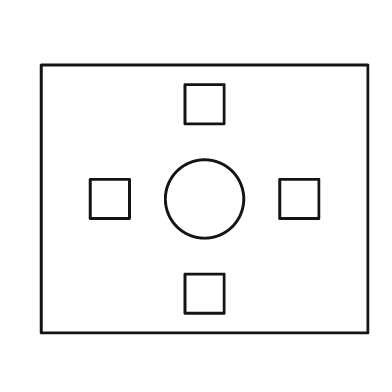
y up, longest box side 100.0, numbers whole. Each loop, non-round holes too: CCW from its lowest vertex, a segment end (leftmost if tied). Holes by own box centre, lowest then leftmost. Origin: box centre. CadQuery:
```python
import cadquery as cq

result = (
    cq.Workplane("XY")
    .moveTo(-50.0, -41.0)
    .lineTo(50.0, -41.0)
    .lineTo(50.0, 41.0)
    .lineTo(-50.0, 41.0)
    .close()
    .moveTo(-6.0, -35.0)
    .lineTo(6.0, -35.0)
    .lineTo(6.0, -23.0)
    .lineTo(-6.0, -23.0)
    .close()
    .moveTo(-35.0, -6.0)
    .lineTo(-23.0, -6.0)
    .lineTo(-23.0, 6.0)
    .lineTo(-35.0, 6.0)
    .close()
    .moveTo(0.0, 0.0)
    .circle(12.0)
    .moveTo(23.0, -6.0)
    .lineTo(35.0, -6.0)
    .lineTo(35.0, 6.0)
    .lineTo(23.0, 6.0)
    .close()
    .moveTo(-6.0, 23.0)
    .lineTo(6.0, 23.0)
    .lineTo(6.0, 35.0)
    .lineTo(-6.0, 35.0)
    .close()
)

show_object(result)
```